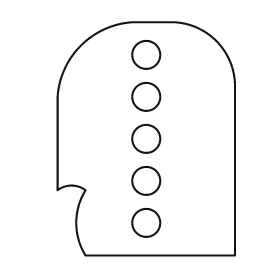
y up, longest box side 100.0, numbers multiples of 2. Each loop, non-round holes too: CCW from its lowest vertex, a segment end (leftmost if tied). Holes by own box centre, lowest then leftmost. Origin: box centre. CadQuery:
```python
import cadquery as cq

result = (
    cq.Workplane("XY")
    .moveTo(-26.0, -50.0)
    .lineTo(38.0, -50.0)
    .lineTo(38.0, 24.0)
    .threePointArc((30.0, 42.0), (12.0, 50.0))
    .lineTo(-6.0, 50.0)
    .threePointArc((-28.0, 40.0), (-38.0, 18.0))
    .lineTo(-38.0, -22.0)
    .threePointArc((-32.0, -20.0), (-26.0, -22.0))
    .threePointArc((-30.0, -36.0), (-26.0, -50.0))
    .close()
    .moveTo(0.0, -36.0)
    .circle(6.0)
    .moveTo(0.0, -18.0)
    .circle(6.0)
    .moveTo(0.0, 0.0)
    .circle(6.0)
    .moveTo(0.0, 18.0)
    .circle(6.0)
    .moveTo(0.0, 36.0)
    .circle(6.0)
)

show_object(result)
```